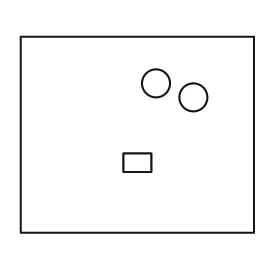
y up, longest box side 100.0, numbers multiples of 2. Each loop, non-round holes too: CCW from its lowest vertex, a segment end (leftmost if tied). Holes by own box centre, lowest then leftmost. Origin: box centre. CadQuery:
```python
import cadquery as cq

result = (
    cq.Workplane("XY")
    .moveTo(-50.0, -42.0)
    .lineTo(50.0, -42.0)
    .lineTo(50.0, 42.0)
    .lineTo(-50.0, 42.0)
    .close()
    .moveTo(-6.0, -16.0)
    .lineTo(6.0, -16.0)
    .lineTo(6.0, -8.0)
    .lineTo(-6.0, -8.0)
    .close()
    .moveTo(24.0, 16.0)
    .circle(6.0)
    .moveTo(8.0, 22.0)
    .circle(6.0)
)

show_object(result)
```